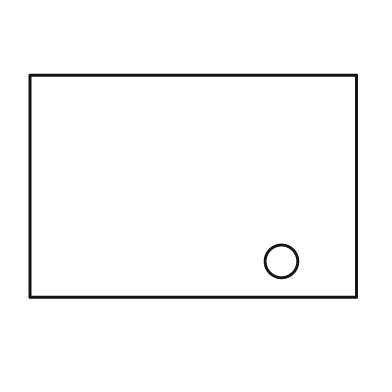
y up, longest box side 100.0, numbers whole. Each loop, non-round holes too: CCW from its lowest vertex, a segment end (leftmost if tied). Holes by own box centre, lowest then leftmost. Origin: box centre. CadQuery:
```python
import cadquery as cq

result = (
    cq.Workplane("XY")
    .moveTo(-50.0, -34.0)
    .lineTo(50.0, -34.0)
    .lineTo(50.0, 34.0)
    .lineTo(-50.0, 34.0)
    .close()
    .moveTo(27.0, -23.0)
    .circle(5.0)
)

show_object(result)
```